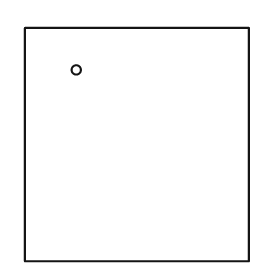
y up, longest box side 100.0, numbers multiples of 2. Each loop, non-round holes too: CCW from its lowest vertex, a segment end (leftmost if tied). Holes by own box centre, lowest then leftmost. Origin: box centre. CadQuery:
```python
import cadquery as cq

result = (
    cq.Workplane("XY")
    .moveTo(-48.0, -50.0)
    .lineTo(48.0, -50.0)
    .lineTo(48.0, 50.0)
    .lineTo(-48.0, 50.0)
    .close()
    .moveTo(-26.0, 32.0)
    .circle(2.0)
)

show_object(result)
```